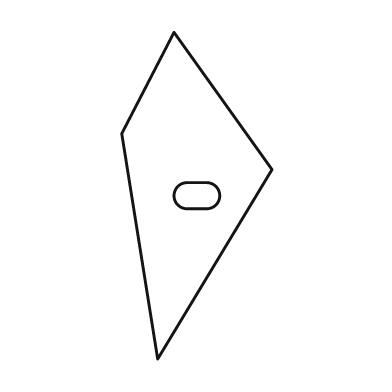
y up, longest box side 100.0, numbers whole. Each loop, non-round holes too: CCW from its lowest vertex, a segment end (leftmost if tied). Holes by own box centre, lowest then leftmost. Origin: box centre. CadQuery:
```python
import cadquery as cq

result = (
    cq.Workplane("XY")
    .moveTo(-12.0, -50.0)
    .lineTo(23.0, 8.0)
    .lineTo(-7.0, 50.0)
    .lineTo(-23.0, 19.0)
    .close()
    .moveTo(-3.0, -4.0)
    .lineTo(3.0, -4.0)
    .threePointArc((7.0, 0.0), (3.0, 4.0))
    .lineTo(-3.0, 4.0)
    .threePointArc((-7.0, 0.0), (-3.0, -4.0))
    .close()
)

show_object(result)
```